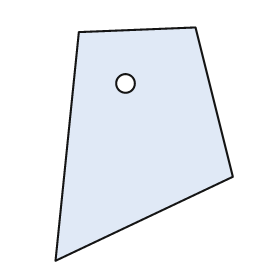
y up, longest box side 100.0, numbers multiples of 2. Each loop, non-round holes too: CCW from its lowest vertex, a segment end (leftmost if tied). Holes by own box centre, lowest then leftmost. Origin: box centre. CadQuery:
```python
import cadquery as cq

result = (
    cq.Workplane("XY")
    .moveTo(-38.0, -50.0)
    .lineTo(38.0, -14.0)
    .lineTo(22.0, 50.0)
    .lineTo(-28.0, 48.0)
    .close()
    .moveTo(-8.0, 26.0)
    .circle(4.0)
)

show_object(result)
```